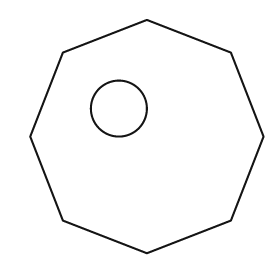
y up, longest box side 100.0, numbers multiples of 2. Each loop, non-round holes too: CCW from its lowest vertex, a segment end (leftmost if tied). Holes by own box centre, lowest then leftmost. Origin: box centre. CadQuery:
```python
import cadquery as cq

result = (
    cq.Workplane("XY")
    .moveTo(0.0, -50.0)
    .lineTo(36.0, -36.0)
    .lineTo(50.0, 0.0)
    .lineTo(36.0, 36.0)
    .lineTo(0.0, 50.0)
    .lineTo(-36.0, 36.0)
    .lineTo(-50.0, 0.0)
    .lineTo(-36.0, -36.0)
    .close()
    .moveTo(-12.0, 12.0)
    .circle(12.0)
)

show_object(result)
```